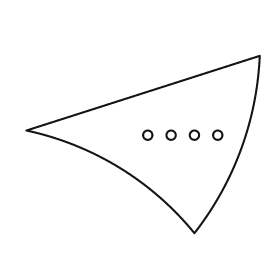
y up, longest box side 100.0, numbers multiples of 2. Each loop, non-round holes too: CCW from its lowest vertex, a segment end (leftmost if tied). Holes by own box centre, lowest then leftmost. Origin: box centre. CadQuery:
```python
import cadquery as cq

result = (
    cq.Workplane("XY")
    .moveTo(22.0, -38.0)
    .threePointArc((42.0, -2.0), (50.0, 38.0))
    .lineTo(-50.0, 6.0)
    .threePointArc((-10.0, -10.0), (22.0, -38.0))
    .close()
    .moveTo(2.0, 4.0)
    .circle(2.0)
    .moveTo(12.0, 4.0)
    .circle(2.0)
    .moveTo(22.0, 4.0)
    .circle(2.0)
    .moveTo(32.0, 4.0)
    .circle(2.0)
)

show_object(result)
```